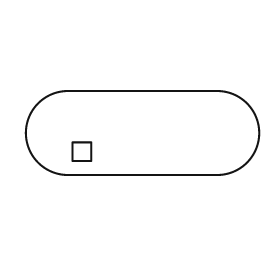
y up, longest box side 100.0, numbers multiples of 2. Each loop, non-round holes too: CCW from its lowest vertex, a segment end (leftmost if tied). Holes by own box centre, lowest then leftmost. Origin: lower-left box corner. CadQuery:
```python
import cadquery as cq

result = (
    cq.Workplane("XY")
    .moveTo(18.0, 0.0)
    .lineTo(82.0, 0.0)
    .threePointArc((100.0, 18.0), (82.0, 36.0))
    .lineTo(18.0, 36.0)
    .threePointArc((0.0, 18.0), (18.0, 0.0))
    .close()
    .moveTo(20.0, 6.0)
    .lineTo(28.0, 6.0)
    .lineTo(28.0, 14.0)
    .lineTo(20.0, 14.0)
    .close()
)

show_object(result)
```